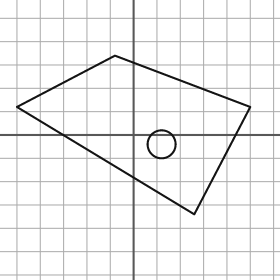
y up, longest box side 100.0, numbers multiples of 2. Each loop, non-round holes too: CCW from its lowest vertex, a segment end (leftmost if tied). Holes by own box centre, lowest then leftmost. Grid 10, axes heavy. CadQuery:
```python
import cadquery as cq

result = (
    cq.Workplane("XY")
    .moveTo(26.0, -34.0)
    .lineTo(50.0, 12.0)
    .lineTo(-8.0, 34.0)
    .lineTo(-50.0, 12.0)
    .close()
    .moveTo(12.0, -4.0)
    .circle(6.0)
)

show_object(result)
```